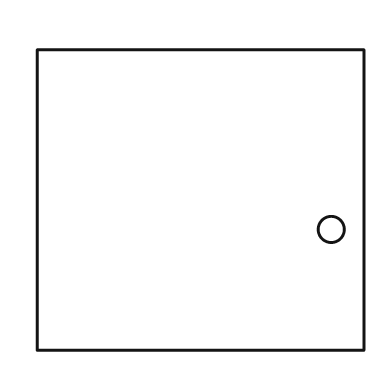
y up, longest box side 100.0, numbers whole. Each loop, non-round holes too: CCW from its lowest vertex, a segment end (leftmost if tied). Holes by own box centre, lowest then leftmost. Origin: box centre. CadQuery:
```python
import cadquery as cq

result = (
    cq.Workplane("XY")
    .moveTo(-50.0, -46.0)
    .lineTo(50.0, -46.0)
    .lineTo(50.0, 46.0)
    .lineTo(-50.0, 46.0)
    .close()
    .moveTo(40.0, -9.0)
    .circle(4.0)
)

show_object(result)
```